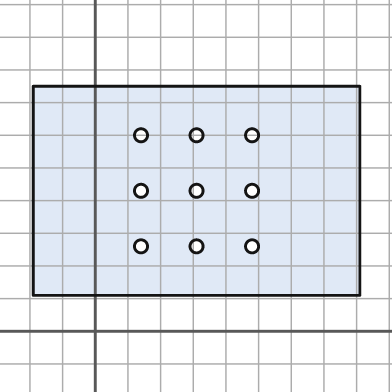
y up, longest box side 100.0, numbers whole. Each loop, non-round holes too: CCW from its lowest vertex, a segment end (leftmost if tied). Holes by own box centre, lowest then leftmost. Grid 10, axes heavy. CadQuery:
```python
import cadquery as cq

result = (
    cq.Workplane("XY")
    .moveTo(-19.0, 11.0)
    .lineTo(81.0, 11.0)
    .lineTo(81.0, 75.0)
    .lineTo(-19.0, 75.0)
    .close()
    .moveTo(14.0, 26.0)
    .circle(2.0)
    .moveTo(31.0, 26.0)
    .circle(2.0)
    .moveTo(48.0, 26.0)
    .circle(2.0)
    .moveTo(14.0, 43.0)
    .circle(2.0)
    .moveTo(31.0, 43.0)
    .circle(2.0)
    .moveTo(48.0, 43.0)
    .circle(2.0)
    .moveTo(14.0, 60.0)
    .circle(2.0)
    .moveTo(31.0, 60.0)
    .circle(2.0)
    .moveTo(48.0, 60.0)
    .circle(2.0)
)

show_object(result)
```